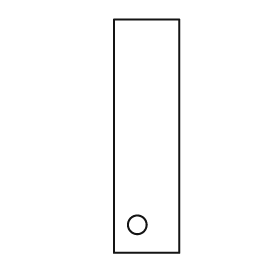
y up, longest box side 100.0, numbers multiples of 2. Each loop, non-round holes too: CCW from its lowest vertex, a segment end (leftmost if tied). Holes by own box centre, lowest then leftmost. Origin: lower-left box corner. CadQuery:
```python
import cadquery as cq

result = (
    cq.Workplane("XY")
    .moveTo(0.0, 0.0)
    .lineTo(28.0, 0.0)
    .lineTo(28.0, 100.0)
    .lineTo(0.0, 100.0)
    .close()
    .moveTo(10.0, 12.0)
    .circle(4.0)
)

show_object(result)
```